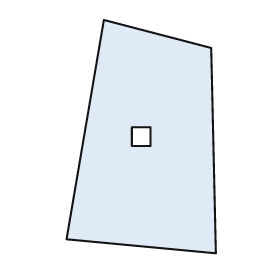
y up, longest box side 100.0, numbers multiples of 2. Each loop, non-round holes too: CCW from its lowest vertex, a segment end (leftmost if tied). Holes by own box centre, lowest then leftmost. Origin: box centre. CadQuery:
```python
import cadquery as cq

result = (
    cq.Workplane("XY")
    .moveTo(32.0, -50.0)
    .lineTo(30.0, 38.0)
    .lineTo(-16.0, 50.0)
    .lineTo(-32.0, -44.0)
    .close()
    .moveTo(-4.0, -4.0)
    .lineTo(4.0, -4.0)
    .lineTo(4.0, 4.0)
    .lineTo(-4.0, 4.0)
    .close()
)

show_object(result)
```